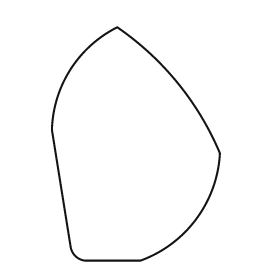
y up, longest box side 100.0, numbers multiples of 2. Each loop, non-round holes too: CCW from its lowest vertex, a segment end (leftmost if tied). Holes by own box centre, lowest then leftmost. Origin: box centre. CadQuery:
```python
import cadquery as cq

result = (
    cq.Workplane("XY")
    .moveTo(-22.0, -50.0)
    .lineTo(2.0, -50.0)
    .threePointArc((26.0, -32.0), (36.0, -4.0))
    .threePointArc((18.0, 26.0), (-8.0, 50.0))
    .threePointArc((-28.0, 32.0), (-36.0, 6.0))
    .lineTo(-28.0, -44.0)
    .threePointArc((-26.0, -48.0), (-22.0, -50.0))
    .close()
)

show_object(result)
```